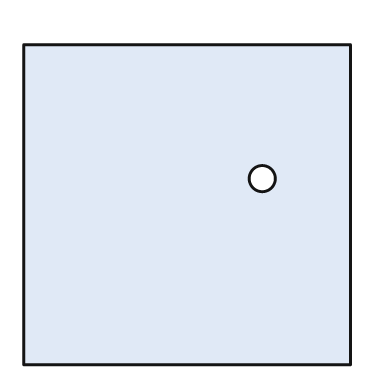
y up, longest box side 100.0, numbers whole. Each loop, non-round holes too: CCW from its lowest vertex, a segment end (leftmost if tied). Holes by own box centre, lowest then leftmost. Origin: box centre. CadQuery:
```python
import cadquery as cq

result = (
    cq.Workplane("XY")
    .moveTo(-50.0, -49.0)
    .lineTo(50.0, -49.0)
    .lineTo(50.0, 49.0)
    .lineTo(-50.0, 49.0)
    .close()
    .moveTo(23.0, 8.0)
    .circle(4.0)
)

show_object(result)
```